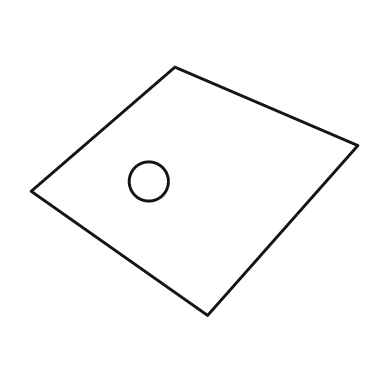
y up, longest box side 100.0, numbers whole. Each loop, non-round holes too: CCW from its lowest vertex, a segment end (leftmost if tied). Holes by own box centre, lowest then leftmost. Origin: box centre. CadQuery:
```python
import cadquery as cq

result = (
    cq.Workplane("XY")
    .moveTo(4.0, -38.0)
    .lineTo(50.0, 14.0)
    .lineTo(-6.0, 38.0)
    .lineTo(-50.0, 0.0)
    .close()
    .moveTo(-14.0, 3.0)
    .circle(6.0)
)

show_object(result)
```